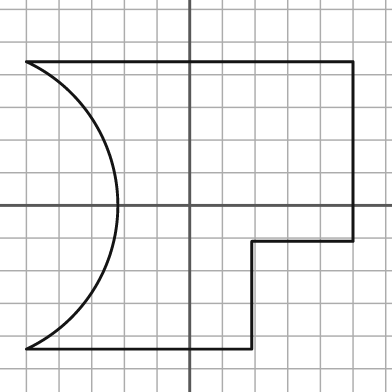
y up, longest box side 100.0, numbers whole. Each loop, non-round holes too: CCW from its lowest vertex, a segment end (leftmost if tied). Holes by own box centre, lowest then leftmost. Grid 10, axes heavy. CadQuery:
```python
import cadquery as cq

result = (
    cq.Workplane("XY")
    .moveTo(-50.0, -44.0)
    .lineTo(19.0, -44.0)
    .lineTo(19.0, -11.0)
    .lineTo(50.0, -11.0)
    .lineTo(50.0, 44.0)
    .lineTo(-50.0, 44.0)
    .threePointArc((-22.0, 0.0), (-50.0, -44.0))
    .close()
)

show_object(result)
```